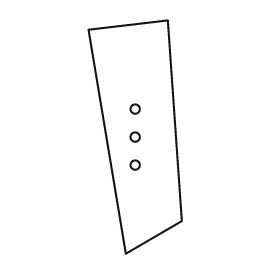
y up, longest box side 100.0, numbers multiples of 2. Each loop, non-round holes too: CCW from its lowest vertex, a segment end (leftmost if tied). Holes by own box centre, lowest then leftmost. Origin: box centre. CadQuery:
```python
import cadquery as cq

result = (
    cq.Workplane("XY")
    .moveTo(-4.0, -50.0)
    .lineTo(20.0, -36.0)
    .lineTo(14.0, 50.0)
    .lineTo(-20.0, 46.0)
    .close()
    .moveTo(0.0, -12.0)
    .circle(2.0)
    .moveTo(0.0, 0.0)
    .circle(2.0)
    .moveTo(0.0, 12.0)
    .circle(2.0)
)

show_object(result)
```